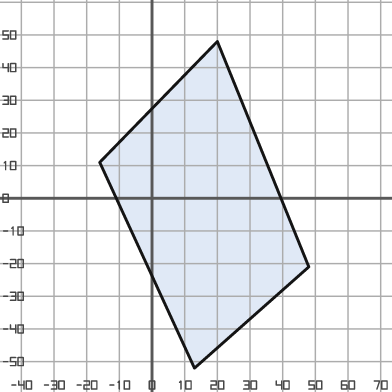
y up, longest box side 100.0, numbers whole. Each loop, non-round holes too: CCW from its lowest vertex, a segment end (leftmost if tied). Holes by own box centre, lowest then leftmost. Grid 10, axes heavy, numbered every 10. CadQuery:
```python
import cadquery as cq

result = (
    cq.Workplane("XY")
    .moveTo(13.0, -52.0)
    .lineTo(48.0, -21.0)
    .lineTo(20.0, 48.0)
    .lineTo(-16.0, 11.0)
    .close()
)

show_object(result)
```